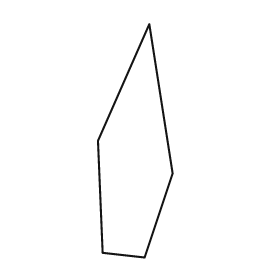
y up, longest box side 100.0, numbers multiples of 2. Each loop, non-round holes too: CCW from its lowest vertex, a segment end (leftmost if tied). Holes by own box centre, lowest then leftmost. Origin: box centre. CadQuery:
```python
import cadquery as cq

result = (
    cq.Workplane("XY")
    .moveTo(4.0, -50.0)
    .lineTo(16.0, -14.0)
    .lineTo(6.0, 50.0)
    .lineTo(-16.0, 0.0)
    .lineTo(-14.0, -48.0)
    .close()
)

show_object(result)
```